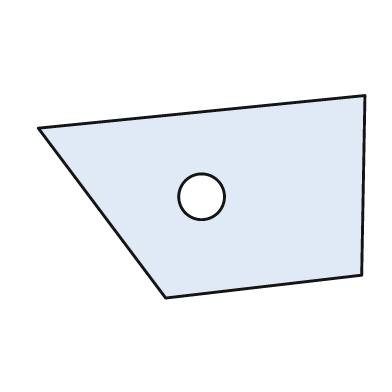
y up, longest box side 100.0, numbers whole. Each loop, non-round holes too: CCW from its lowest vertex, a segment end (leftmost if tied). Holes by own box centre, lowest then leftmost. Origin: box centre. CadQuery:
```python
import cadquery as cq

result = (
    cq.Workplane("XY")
    .moveTo(-11.0, -31.0)
    .lineTo(49.0, -24.0)
    .lineTo(50.0, 31.0)
    .lineTo(-50.0, 21.0)
    .close()
    .moveTo(0.0, 0.0)
    .circle(7.0)
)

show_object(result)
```